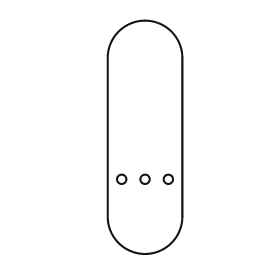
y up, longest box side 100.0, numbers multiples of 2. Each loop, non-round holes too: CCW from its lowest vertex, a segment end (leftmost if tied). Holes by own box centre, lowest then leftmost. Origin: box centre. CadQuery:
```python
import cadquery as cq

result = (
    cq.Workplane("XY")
    .moveTo(-16.0, -34.0)
    .threePointArc((0.0, -50.0), (16.0, -34.0))
    .lineTo(16.0, 34.0)
    .threePointArc((0.0, 50.0), (-16.0, 34.0))
    .close()
    .moveTo(-10.0, -18.0)
    .circle(2.0)
    .moveTo(0.0, -18.0)
    .circle(2.0)
    .moveTo(10.0, -18.0)
    .circle(2.0)
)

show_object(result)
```